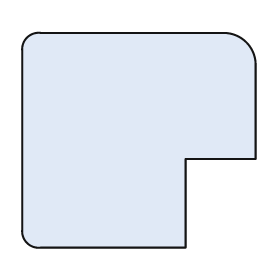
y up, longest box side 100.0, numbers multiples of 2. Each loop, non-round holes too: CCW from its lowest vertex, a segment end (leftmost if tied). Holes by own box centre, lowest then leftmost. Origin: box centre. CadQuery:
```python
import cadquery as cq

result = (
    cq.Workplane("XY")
    .moveTo(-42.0, -46.0)
    .lineTo(20.0, -46.0)
    .lineTo(20.0, -8.0)
    .lineTo(50.0, -8.0)
    .lineTo(50.0, 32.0)
    .threePointArc((46.0, 42.0), (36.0, 46.0))
    .lineTo(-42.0, 46.0)
    .threePointArc((-48.0, 44.0), (-50.0, 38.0))
    .lineTo(-50.0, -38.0)
    .threePointArc((-48.0, -44.0), (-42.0, -46.0))
    .close()
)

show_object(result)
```